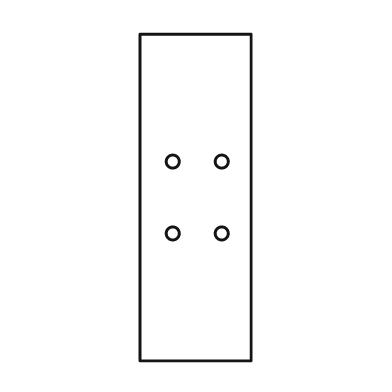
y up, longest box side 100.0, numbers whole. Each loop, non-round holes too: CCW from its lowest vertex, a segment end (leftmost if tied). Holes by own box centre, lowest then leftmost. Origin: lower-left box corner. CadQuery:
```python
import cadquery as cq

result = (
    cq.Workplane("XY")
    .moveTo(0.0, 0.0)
    .lineTo(34.0, 0.0)
    .lineTo(34.0, 100.0)
    .lineTo(0.0, 100.0)
    .close()
    .moveTo(10.0, 39.0)
    .circle(2.0)
    .moveTo(25.0, 39.0)
    .circle(2.0)
    .moveTo(10.0, 61.0)
    .circle(2.0)
    .moveTo(25.0, 61.0)
    .circle(2.0)
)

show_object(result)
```